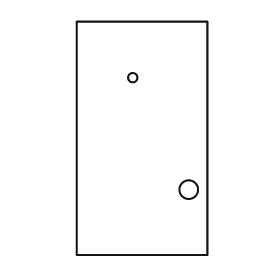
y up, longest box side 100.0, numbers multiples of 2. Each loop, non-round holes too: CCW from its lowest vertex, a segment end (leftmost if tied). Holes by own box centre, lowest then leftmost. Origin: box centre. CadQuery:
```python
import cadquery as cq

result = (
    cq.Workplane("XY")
    .moveTo(-28.0, -50.0)
    .lineTo(28.0, -50.0)
    .lineTo(28.0, 50.0)
    .lineTo(-28.0, 50.0)
    .close()
    .moveTo(20.0, -22.0)
    .circle(4.0)
    .moveTo(-4.0, 26.0)
    .circle(2.0)
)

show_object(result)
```